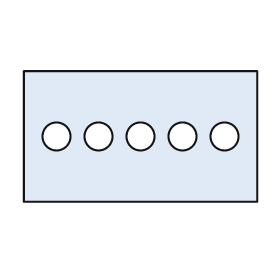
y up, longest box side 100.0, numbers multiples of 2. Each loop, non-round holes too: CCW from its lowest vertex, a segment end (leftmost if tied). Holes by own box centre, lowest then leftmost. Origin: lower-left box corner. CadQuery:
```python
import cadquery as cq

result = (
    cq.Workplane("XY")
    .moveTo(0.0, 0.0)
    .lineTo(100.0, 0.0)
    .lineTo(100.0, 56.0)
    .lineTo(0.0, 56.0)
    .close()
    .moveTo(14.0, 28.0)
    .circle(6.0)
    .moveTo(32.0, 28.0)
    .circle(6.0)
    .moveTo(50.0, 28.0)
    .circle(6.0)
    .moveTo(68.0, 28.0)
    .circle(6.0)
    .moveTo(86.0, 28.0)
    .circle(6.0)
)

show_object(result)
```